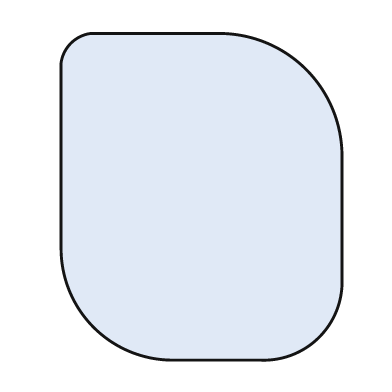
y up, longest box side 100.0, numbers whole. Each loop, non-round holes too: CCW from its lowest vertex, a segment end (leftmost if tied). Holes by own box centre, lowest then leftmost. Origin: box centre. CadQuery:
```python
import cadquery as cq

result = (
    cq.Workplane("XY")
    .moveTo(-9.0, -50.0)
    .lineTo(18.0, -50.0)
    .threePointArc((36.0, -43.0), (43.0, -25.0))
    .lineTo(43.0, 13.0)
    .threePointArc((32.0, 39.0), (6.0, 50.0))
    .lineTo(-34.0, 50.0)
    .threePointArc((-40.0, 47.0), (-43.0, 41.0))
    .lineTo(-43.0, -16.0)
    .threePointArc((-33.0, -40.0), (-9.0, -50.0))
    .close()
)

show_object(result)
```